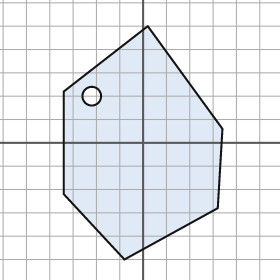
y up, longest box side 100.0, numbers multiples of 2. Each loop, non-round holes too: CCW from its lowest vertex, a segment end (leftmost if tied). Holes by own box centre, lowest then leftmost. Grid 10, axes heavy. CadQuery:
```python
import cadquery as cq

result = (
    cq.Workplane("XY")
    .moveTo(-8.0, -50.0)
    .lineTo(32.0, -28.0)
    .lineTo(34.0, 6.0)
    .lineTo(2.0, 50.0)
    .lineTo(-34.0, 22.0)
    .lineTo(-34.0, -22.0)
    .close()
    .moveTo(-22.0, 20.0)
    .circle(4.0)
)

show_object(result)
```